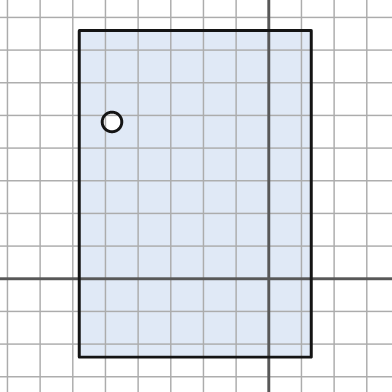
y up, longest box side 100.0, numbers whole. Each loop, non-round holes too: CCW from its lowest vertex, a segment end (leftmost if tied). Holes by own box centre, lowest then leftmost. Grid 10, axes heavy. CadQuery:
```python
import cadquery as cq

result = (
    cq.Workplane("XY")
    .moveTo(-58.0, -24.0)
    .lineTo(13.0, -24.0)
    .lineTo(13.0, 76.0)
    .lineTo(-58.0, 76.0)
    .close()
    .moveTo(-48.0, 48.0)
    .circle(3.0)
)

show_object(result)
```